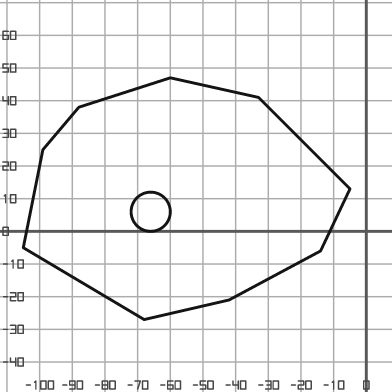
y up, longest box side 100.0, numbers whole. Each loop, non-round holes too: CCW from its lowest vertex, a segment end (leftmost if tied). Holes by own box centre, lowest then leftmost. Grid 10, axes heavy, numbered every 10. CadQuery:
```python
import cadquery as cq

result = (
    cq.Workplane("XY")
    .moveTo(-68.0, -27.0)
    .lineTo(-42.0, -21.0)
    .lineTo(-14.0, -6.0)
    .lineTo(-5.0, 13.0)
    .lineTo(-33.0, 41.0)
    .lineTo(-60.0, 47.0)
    .lineTo(-88.0, 38.0)
    .lineTo(-99.0, 25.0)
    .lineTo(-105.0, -5.0)
    .close()
    .moveTo(-66.0, 6.0)
    .circle(6.0)
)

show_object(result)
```